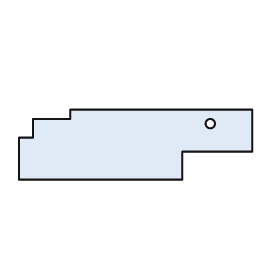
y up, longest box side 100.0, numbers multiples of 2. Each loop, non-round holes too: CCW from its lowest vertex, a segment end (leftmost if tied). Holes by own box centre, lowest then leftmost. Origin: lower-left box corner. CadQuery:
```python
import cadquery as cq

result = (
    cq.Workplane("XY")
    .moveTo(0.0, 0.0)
    .lineTo(70.0, 0.0)
    .lineTo(70.0, 12.0)
    .lineTo(100.0, 12.0)
    .lineTo(100.0, 30.0)
    .lineTo(22.0, 30.0)
    .lineTo(22.0, 26.0)
    .lineTo(6.0, 26.0)
    .lineTo(6.0, 18.0)
    .lineTo(0.0, 18.0)
    .close()
    .moveTo(82.0, 24.0)
    .circle(2.0)
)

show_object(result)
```